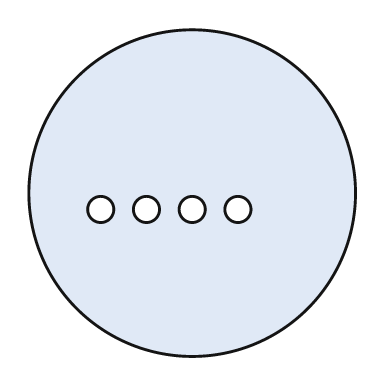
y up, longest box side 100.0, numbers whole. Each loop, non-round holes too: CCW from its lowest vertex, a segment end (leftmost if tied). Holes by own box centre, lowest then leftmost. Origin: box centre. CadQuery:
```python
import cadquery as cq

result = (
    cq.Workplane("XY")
    .moveTo(0.0, 0.0)
    .circle(50.0)
    .moveTo(-28.0, -5.0)
    .circle(4.0)
    .moveTo(-14.0, -5.0)
    .circle(4.0)
    .moveTo(0.0, -5.0)
    .circle(4.0)
    .moveTo(14.0, -5.0)
    .circle(4.0)
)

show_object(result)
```